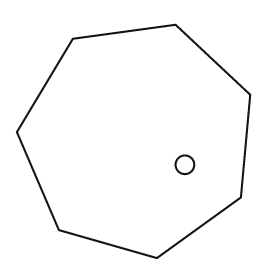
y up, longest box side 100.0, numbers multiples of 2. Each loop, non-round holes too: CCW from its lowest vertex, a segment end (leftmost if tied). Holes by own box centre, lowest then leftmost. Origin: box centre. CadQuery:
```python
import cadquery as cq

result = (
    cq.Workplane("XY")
    .moveTo(10.0, -50.0)
    .lineTo(46.0, -24.0)
    .lineTo(50.0, 20.0)
    .lineTo(18.0, 50.0)
    .lineTo(-26.0, 44.0)
    .lineTo(-50.0, 4.0)
    .lineTo(-32.0, -38.0)
    .close()
    .moveTo(22.0, -10.0)
    .circle(4.0)
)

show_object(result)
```